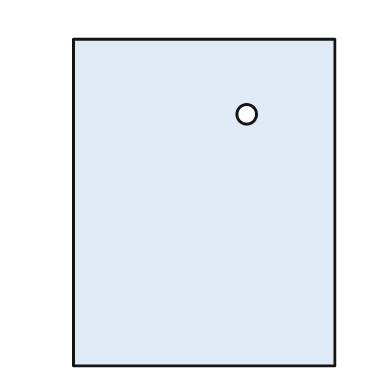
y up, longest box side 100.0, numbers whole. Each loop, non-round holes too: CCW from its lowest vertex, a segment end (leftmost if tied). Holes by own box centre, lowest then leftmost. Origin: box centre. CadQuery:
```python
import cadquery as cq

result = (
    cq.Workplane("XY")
    .moveTo(-40.0, -50.0)
    .lineTo(40.0, -50.0)
    .lineTo(40.0, 50.0)
    .lineTo(-40.0, 50.0)
    .close()
    .moveTo(13.0, 27.0)
    .circle(3.0)
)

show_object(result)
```